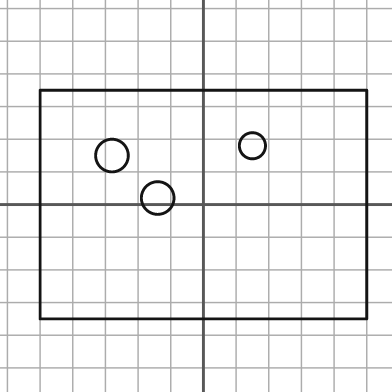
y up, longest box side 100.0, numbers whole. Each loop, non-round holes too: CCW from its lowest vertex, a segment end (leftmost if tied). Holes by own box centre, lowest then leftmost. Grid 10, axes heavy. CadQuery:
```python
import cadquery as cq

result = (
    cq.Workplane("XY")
    .moveTo(-50.0, -35.0)
    .lineTo(50.0, -35.0)
    .lineTo(50.0, 35.0)
    .lineTo(-50.0, 35.0)
    .close()
    .moveTo(-14.0, 2.0)
    .circle(5.0)
    .moveTo(-28.0, 15.0)
    .circle(5.0)
    .moveTo(15.0, 18.0)
    .circle(4.0)
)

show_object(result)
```